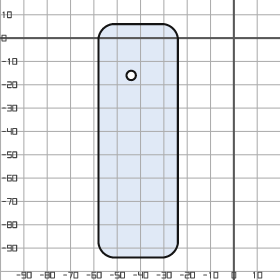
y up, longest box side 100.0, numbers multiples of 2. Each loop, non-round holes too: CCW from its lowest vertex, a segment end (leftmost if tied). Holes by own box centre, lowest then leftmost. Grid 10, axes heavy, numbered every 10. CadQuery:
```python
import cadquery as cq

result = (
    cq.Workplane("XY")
    .moveTo(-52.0, -94.0)
    .lineTo(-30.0, -94.0)
    .threePointArc((-26.0, -92.0), (-24.0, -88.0))
    .lineTo(-24.0, 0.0)
    .threePointArc((-26.0, 4.0), (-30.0, 6.0))
    .lineTo(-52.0, 6.0)
    .threePointArc((-56.0, 4.0), (-58.0, 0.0))
    .lineTo(-58.0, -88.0)
    .threePointArc((-56.0, -92.0), (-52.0, -94.0))
    .close()
    .moveTo(-44.0, -16.0)
    .circle(2.0)
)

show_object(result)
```